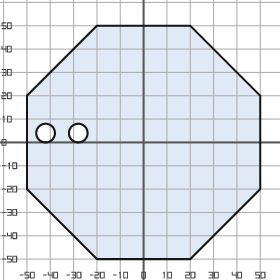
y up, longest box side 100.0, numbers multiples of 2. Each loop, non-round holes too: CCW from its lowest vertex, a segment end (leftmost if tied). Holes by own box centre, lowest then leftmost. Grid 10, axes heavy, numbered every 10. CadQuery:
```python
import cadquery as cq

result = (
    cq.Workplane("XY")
    .moveTo(-20.0, -50.0)
    .lineTo(20.0, -50.0)
    .lineTo(50.0, -20.0)
    .lineTo(50.0, 20.0)
    .lineTo(20.0, 50.0)
    .lineTo(-20.0, 50.0)
    .lineTo(-50.0, 20.0)
    .lineTo(-50.0, -20.0)
    .close()
    .moveTo(-42.0, 4.0)
    .circle(4.0)
    .moveTo(-28.0, 4.0)
    .circle(4.0)
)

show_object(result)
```